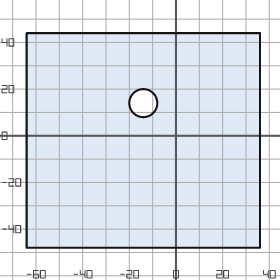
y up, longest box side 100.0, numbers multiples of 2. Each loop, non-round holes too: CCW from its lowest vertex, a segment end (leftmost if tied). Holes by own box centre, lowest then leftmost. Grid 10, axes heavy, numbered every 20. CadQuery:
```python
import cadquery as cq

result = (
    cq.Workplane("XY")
    .moveTo(-64.0, -48.0)
    .lineTo(36.0, -48.0)
    .lineTo(36.0, 44.0)
    .lineTo(-64.0, 44.0)
    .close()
    .moveTo(-14.0, 14.0)
    .circle(6.0)
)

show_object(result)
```